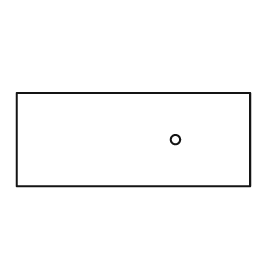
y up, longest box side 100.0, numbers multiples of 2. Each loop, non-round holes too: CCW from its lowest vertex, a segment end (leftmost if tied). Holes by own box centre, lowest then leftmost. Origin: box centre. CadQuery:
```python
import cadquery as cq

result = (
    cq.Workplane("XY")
    .moveTo(-50.0, -20.0)
    .lineTo(50.0, -20.0)
    .lineTo(50.0, 20.0)
    .lineTo(-50.0, 20.0)
    .close()
    .moveTo(18.0, 0.0)
    .circle(2.0)
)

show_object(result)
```